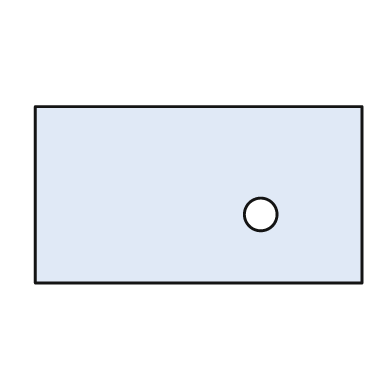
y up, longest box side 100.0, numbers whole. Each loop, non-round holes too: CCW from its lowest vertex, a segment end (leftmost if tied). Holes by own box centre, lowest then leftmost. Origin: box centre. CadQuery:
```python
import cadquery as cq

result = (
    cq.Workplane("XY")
    .moveTo(-50.0, -27.0)
    .lineTo(50.0, -27.0)
    .lineTo(50.0, 27.0)
    .lineTo(-50.0, 27.0)
    .close()
    .moveTo(19.0, -6.0)
    .circle(5.0)
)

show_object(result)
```